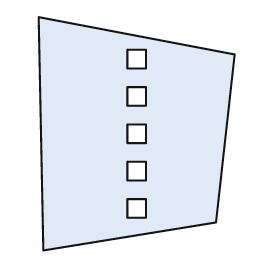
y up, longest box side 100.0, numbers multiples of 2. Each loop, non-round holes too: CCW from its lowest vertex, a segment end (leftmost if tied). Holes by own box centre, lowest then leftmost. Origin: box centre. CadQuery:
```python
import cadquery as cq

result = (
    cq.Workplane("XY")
    .moveTo(-40.0, -50.0)
    .lineTo(34.0, -38.0)
    .lineTo(42.0, 34.0)
    .lineTo(-42.0, 50.0)
    .close()
    .moveTo(-4.0, -36.0)
    .lineTo(4.0, -36.0)
    .lineTo(4.0, -28.0)
    .lineTo(-4.0, -28.0)
    .close()
    .moveTo(-4.0, -20.0)
    .lineTo(4.0, -20.0)
    .lineTo(4.0, -12.0)
    .lineTo(-4.0, -12.0)
    .close()
    .moveTo(-4.0, -4.0)
    .lineTo(4.0, -4.0)
    .lineTo(4.0, 4.0)
    .lineTo(-4.0, 4.0)
    .close()
    .moveTo(-4.0, 12.0)
    .lineTo(4.0, 12.0)
    .lineTo(4.0, 20.0)
    .lineTo(-4.0, 20.0)
    .close()
    .moveTo(-4.0, 28.0)
    .lineTo(4.0, 28.0)
    .lineTo(4.0, 36.0)
    .lineTo(-4.0, 36.0)
    .close()
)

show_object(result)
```